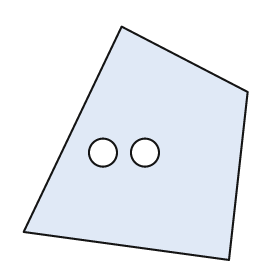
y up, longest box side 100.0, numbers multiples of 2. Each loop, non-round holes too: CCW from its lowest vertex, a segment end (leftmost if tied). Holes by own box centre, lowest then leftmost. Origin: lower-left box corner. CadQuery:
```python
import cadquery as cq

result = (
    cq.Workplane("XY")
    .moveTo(88.0, 0.0)
    .lineTo(96.0, 72.0)
    .lineTo(42.0, 100.0)
    .lineTo(0.0, 12.0)
    .close()
    .moveTo(34.0, 46.0)
    .circle(6.0)
    .moveTo(52.0, 46.0)
    .circle(6.0)
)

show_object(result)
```